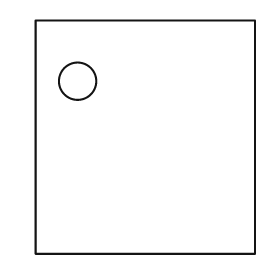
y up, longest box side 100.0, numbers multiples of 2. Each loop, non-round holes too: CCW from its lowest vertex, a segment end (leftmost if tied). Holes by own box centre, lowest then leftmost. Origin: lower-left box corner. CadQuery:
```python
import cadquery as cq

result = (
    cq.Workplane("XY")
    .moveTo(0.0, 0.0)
    .lineTo(94.0, 0.0)
    .lineTo(94.0, 100.0)
    .lineTo(0.0, 100.0)
    .close()
    .moveTo(18.0, 74.0)
    .circle(8.0)
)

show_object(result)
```